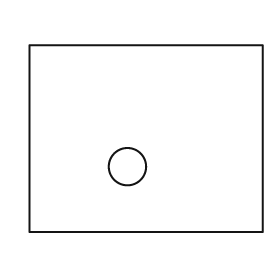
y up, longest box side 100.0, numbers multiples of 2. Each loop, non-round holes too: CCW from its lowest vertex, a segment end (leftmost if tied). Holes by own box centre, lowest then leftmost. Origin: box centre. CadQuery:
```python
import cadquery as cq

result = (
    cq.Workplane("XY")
    .moveTo(-50.0, -40.0)
    .lineTo(50.0, -40.0)
    .lineTo(50.0, 40.0)
    .lineTo(-50.0, 40.0)
    .close()
    .moveTo(-8.0, -12.0)
    .circle(8.0)
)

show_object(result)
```